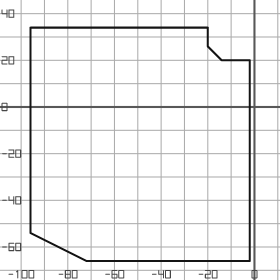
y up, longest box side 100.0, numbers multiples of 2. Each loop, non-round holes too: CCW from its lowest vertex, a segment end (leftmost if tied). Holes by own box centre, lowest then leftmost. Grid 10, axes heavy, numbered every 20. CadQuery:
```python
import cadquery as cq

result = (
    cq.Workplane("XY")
    .moveTo(-72.0, -66.0)
    .lineTo(-2.0, -66.0)
    .lineTo(-2.0, 20.0)
    .lineTo(-14.0, 20.0)
    .lineTo(-20.0, 26.0)
    .lineTo(-20.0, 34.0)
    .lineTo(-96.0, 34.0)
    .lineTo(-96.0, -54.0)
    .close()
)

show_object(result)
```